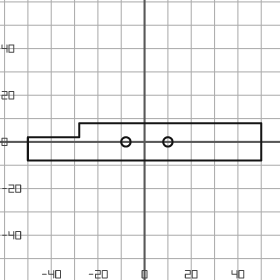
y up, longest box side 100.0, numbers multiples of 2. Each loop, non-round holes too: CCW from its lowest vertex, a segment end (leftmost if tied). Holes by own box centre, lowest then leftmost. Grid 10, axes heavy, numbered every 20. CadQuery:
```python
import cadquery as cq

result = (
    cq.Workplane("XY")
    .moveTo(-50.0, -8.0)
    .lineTo(50.0, -8.0)
    .lineTo(50.0, 8.0)
    .lineTo(-28.0, 8.0)
    .lineTo(-28.0, 2.0)
    .lineTo(-50.0, 2.0)
    .close()
    .moveTo(-8.0, 0.0)
    .circle(2.0)
    .moveTo(10.0, 0.0)
    .circle(2.0)
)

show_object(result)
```